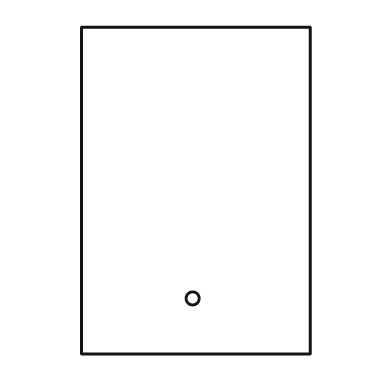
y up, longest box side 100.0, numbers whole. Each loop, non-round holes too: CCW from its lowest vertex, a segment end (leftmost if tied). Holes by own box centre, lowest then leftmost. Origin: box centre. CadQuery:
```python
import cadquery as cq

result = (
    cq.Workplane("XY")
    .moveTo(-35.0, -50.0)
    .lineTo(35.0, -50.0)
    .lineTo(35.0, 50.0)
    .lineTo(-35.0, 50.0)
    .close()
    .moveTo(-1.0, -33.0)
    .circle(2.0)
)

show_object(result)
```